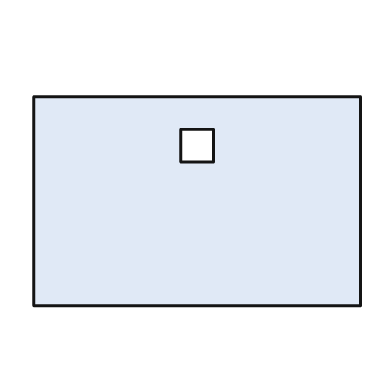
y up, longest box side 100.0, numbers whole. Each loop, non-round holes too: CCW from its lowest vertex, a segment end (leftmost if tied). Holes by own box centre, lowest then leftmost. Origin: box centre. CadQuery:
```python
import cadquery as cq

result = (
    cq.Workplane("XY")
    .moveTo(-50.0, -32.0)
    .lineTo(50.0, -32.0)
    .lineTo(50.0, 32.0)
    .lineTo(-50.0, 32.0)
    .close()
    .moveTo(-5.0, 12.0)
    .lineTo(5.0, 12.0)
    .lineTo(5.0, 22.0)
    .lineTo(-5.0, 22.0)
    .close()
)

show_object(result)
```